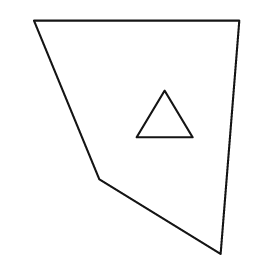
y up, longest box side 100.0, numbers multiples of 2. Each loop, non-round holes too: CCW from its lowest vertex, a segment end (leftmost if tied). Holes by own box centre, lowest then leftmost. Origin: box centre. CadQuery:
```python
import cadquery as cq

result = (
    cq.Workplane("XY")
    .moveTo(36.0, -50.0)
    .lineTo(44.0, 50.0)
    .lineTo(-44.0, 50.0)
    .lineTo(-16.0, -18.0)
    .close()
    .moveTo(0.0, 0.0)
    .lineTo(24.0, 0.0)
    .lineTo(12.0, 20.0)
    .close()
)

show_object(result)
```